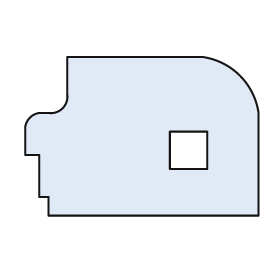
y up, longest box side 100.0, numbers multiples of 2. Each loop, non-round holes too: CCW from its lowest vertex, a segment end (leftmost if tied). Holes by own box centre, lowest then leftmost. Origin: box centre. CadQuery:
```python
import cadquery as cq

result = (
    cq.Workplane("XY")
    .moveTo(-40.0, -34.0)
    .lineTo(50.0, -34.0)
    .lineTo(50.0, 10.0)
    .threePointArc((42.0, 26.0), (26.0, 34.0))
    .lineTo(-32.0, 34.0)
    .lineTo(-32.0, 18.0)
    .threePointArc((-34.0, 12.0), (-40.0, 10.0))
    .lineTo(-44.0, 10.0)
    .threePointArc((-48.0, 8.0), (-50.0, 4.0))
    .lineTo(-50.0, -8.0)
    .lineTo(-44.0, -8.0)
    .lineTo(-44.0, -26.0)
    .lineTo(-40.0, -26.0)
    .close()
    .moveTo(12.0, -14.0)
    .lineTo(28.0, -14.0)
    .lineTo(28.0, 2.0)
    .lineTo(12.0, 2.0)
    .close()
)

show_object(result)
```